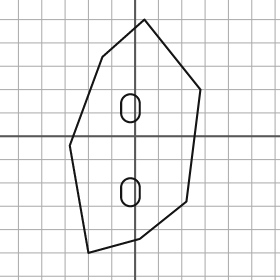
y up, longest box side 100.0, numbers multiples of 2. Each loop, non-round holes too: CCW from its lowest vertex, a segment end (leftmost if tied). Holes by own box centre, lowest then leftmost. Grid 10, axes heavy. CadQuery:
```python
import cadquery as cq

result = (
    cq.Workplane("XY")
    .moveTo(-20.0, -50.0)
    .lineTo(2.0, -44.0)
    .lineTo(22.0, -28.0)
    .lineTo(28.0, 20.0)
    .lineTo(4.0, 50.0)
    .lineTo(-14.0, 34.0)
    .lineTo(-28.0, -4.0)
    .close()
    .moveTo(-6.0, -26.0)
    .threePointArc((-2.0, -30.0), (2.0, -26.0))
    .lineTo(2.0, -22.0)
    .threePointArc((-2.0, -18.0), (-6.0, -22.0))
    .close()
    .moveTo(-6.0, 10.0)
    .threePointArc((-2.0, 6.0), (2.0, 10.0))
    .lineTo(2.0, 14.0)
    .threePointArc((-2.0, 18.0), (-6.0, 14.0))
    .close()
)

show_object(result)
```